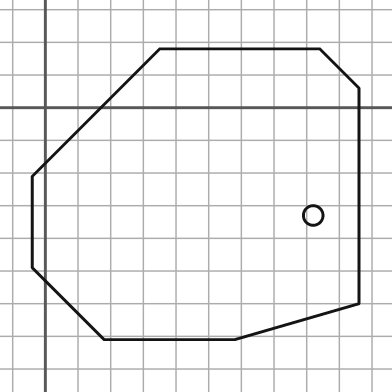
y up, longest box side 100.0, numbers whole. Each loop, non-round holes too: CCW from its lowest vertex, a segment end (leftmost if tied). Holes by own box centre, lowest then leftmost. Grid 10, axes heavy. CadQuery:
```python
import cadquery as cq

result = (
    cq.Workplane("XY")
    .moveTo(18.0, -71.0)
    .lineTo(58.0, -71.0)
    .lineTo(96.0, -60.0)
    .lineTo(96.0, 6.0)
    .lineTo(84.0, 18.0)
    .lineTo(35.0, 18.0)
    .lineTo(-4.0, -21.0)
    .lineTo(-4.0, -49.0)
    .close()
    .moveTo(82.0, -33.0)
    .circle(3.0)
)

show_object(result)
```